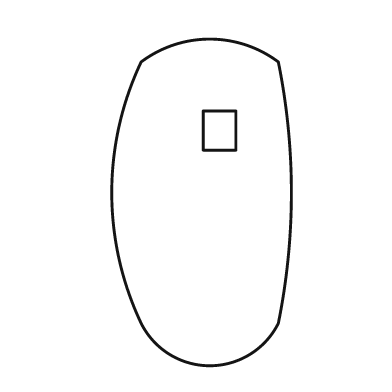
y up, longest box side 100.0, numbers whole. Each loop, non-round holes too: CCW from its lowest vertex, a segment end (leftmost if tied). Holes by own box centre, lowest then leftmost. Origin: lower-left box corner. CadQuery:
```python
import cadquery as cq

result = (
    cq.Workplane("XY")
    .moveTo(9.0, 13.0)
    .threePointArc((30.0, 0.0), (51.0, 13.0))
    .threePointArc((55.0, 53.0), (51.0, 93.0))
    .threePointArc((30.0, 100.0), (9.0, 93.0))
    .threePointArc((0.0, 53.0), (9.0, 13.0))
    .close()
    .moveTo(28.0, 66.0)
    .lineTo(38.0, 66.0)
    .lineTo(38.0, 78.0)
    .lineTo(28.0, 78.0)
    .close()
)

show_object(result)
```